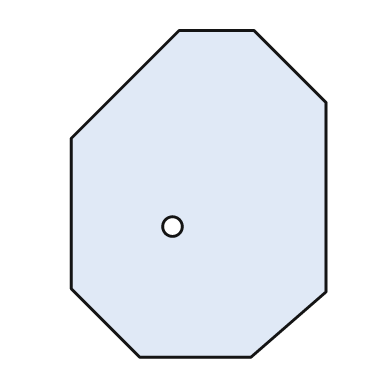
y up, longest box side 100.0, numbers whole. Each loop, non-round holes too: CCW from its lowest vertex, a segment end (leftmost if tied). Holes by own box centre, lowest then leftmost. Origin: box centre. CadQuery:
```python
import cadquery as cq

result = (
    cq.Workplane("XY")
    .moveTo(-18.0, -50.0)
    .lineTo(16.0, -50.0)
    .lineTo(39.0, -30.0)
    .lineTo(39.0, 28.0)
    .lineTo(17.0, 50.0)
    .lineTo(-6.0, 50.0)
    .lineTo(-39.0, 17.0)
    .lineTo(-39.0, -29.0)
    .close()
    .moveTo(-8.0, -10.0)
    .circle(3.0)
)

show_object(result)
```